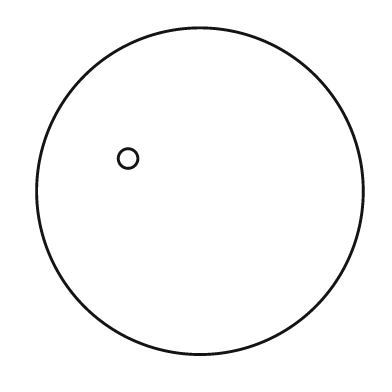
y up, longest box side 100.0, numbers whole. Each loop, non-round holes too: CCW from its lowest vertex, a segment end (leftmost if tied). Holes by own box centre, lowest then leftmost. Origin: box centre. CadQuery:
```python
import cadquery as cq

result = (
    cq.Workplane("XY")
    .moveTo(0.0, 0.0)
    .circle(50.0)
    .moveTo(-22.0, 10.0)
    .circle(3.0)
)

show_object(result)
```